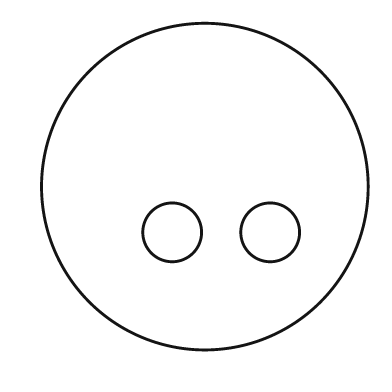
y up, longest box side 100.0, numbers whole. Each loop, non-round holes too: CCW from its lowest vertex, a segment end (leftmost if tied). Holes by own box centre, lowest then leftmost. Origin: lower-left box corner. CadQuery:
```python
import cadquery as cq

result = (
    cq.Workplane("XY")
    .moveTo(50.0, 50.0)
    .circle(50.0)
    .moveTo(40.0, 36.0)
    .circle(9.0)
    .moveTo(70.0, 36.0)
    .circle(9.0)
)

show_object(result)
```